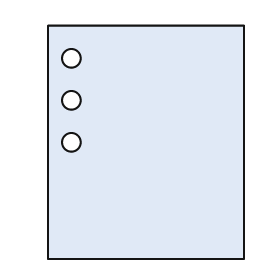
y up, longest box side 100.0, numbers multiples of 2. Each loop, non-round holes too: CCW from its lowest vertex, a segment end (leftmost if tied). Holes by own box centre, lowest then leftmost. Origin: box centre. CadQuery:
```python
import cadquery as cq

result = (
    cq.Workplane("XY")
    .moveTo(-42.0, -50.0)
    .lineTo(42.0, -50.0)
    .lineTo(42.0, 50.0)
    .lineTo(-42.0, 50.0)
    .close()
    .moveTo(-32.0, 0.0)
    .circle(4.0)
    .moveTo(-32.0, 18.0)
    .circle(4.0)
    .moveTo(-32.0, 36.0)
    .circle(4.0)
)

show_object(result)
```